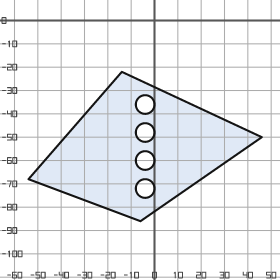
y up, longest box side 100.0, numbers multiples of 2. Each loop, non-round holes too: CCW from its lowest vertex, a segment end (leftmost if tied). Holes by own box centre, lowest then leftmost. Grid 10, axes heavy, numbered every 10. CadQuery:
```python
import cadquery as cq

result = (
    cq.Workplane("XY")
    .moveTo(-6.0, -86.0)
    .lineTo(46.0, -50.0)
    .lineTo(-14.0, -22.0)
    .lineTo(-54.0, -68.0)
    .close()
    .moveTo(-4.0, -72.0)
    .circle(4.0)
    .moveTo(-4.0, -60.0)
    .circle(4.0)
    .moveTo(-4.0, -48.0)
    .circle(4.0)
    .moveTo(-4.0, -36.0)
    .circle(4.0)
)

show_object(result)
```